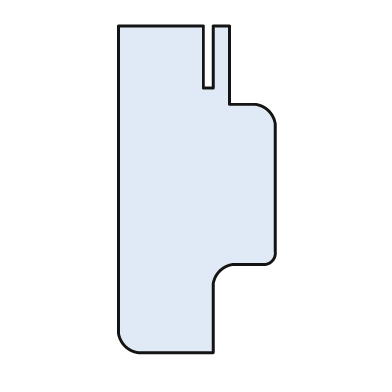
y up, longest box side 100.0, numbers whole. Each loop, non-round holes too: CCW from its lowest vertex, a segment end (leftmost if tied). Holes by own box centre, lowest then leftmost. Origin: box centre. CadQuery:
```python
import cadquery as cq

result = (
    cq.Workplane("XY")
    .moveTo(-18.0, -50.0)
    .lineTo(5.0, -50.0)
    .lineTo(5.0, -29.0)
    .threePointArc((7.0, -25.0), (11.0, -23.0))
    .lineTo(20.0, -23.0)
    .threePointArc((23.0, -22.0), (24.0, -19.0))
    .lineTo(24.0, 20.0)
    .threePointArc((22.0, 24.0), (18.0, 26.0))
    .lineTo(10.0, 26.0)
    .lineTo(10.0, 50.0)
    .lineTo(5.0, 50.0)
    .lineTo(5.0, 31.0)
    .lineTo(2.0, 31.0)
    .lineTo(2.0, 50.0)
    .lineTo(-24.0, 50.0)
    .lineTo(-24.0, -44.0)
    .threePointArc((-22.0, -48.0), (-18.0, -50.0))
    .close()
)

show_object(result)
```